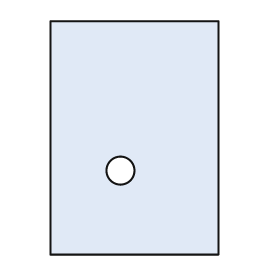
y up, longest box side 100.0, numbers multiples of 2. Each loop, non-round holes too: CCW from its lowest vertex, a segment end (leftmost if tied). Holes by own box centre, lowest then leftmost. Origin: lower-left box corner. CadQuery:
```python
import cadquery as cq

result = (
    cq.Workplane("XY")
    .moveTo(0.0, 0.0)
    .lineTo(72.0, 0.0)
    .lineTo(72.0, 100.0)
    .lineTo(0.0, 100.0)
    .close()
    .moveTo(30.0, 36.0)
    .circle(6.0)
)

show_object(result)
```